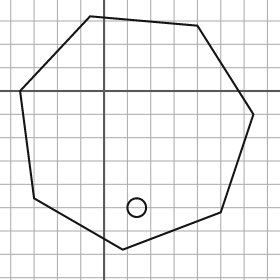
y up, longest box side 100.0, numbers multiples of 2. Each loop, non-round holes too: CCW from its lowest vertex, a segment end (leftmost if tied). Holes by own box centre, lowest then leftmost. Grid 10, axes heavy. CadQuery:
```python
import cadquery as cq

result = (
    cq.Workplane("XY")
    .moveTo(8.0, -68.0)
    .lineTo(50.0, -52.0)
    .lineTo(64.0, -10.0)
    .lineTo(40.0, 28.0)
    .lineTo(-6.0, 32.0)
    .lineTo(-36.0, 0.0)
    .lineTo(-30.0, -46.0)
    .close()
    .moveTo(14.0, -50.0)
    .circle(4.0)
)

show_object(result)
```